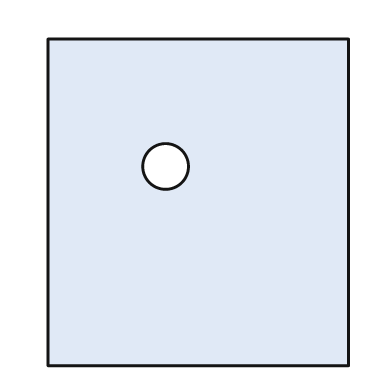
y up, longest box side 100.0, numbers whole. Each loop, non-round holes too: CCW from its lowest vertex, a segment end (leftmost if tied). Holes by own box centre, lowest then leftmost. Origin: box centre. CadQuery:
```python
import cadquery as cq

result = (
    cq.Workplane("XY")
    .moveTo(-46.0, -50.0)
    .lineTo(46.0, -50.0)
    .lineTo(46.0, 50.0)
    .lineTo(-46.0, 50.0)
    .close()
    .moveTo(-10.0, 11.0)
    .circle(7.0)
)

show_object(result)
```